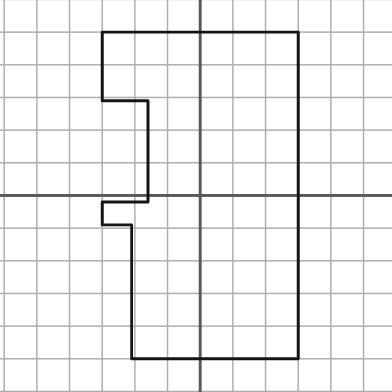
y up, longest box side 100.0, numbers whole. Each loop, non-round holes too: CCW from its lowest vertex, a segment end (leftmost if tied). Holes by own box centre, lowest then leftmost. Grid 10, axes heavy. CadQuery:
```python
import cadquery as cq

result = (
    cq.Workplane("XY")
    .moveTo(-21.0, -50.0)
    .lineTo(30.0, -50.0)
    .lineTo(30.0, 50.0)
    .lineTo(-30.0, 50.0)
    .lineTo(-30.0, 29.0)
    .lineTo(-16.0, 29.0)
    .lineTo(-16.0, -2.0)
    .lineTo(-30.0, -2.0)
    .lineTo(-30.0, -9.0)
    .lineTo(-21.0, -9.0)
    .close()
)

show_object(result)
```